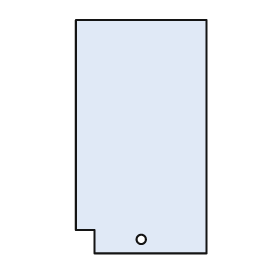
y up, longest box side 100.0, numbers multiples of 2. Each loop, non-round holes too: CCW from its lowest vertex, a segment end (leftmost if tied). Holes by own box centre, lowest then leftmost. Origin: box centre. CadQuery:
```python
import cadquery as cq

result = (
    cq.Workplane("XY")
    .moveTo(-20.0, -50.0)
    .lineTo(28.0, -50.0)
    .lineTo(28.0, 50.0)
    .lineTo(-28.0, 50.0)
    .lineTo(-28.0, -40.0)
    .lineTo(-20.0, -40.0)
    .close()
    .moveTo(0.0, -44.0)
    .circle(2.0)
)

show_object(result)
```